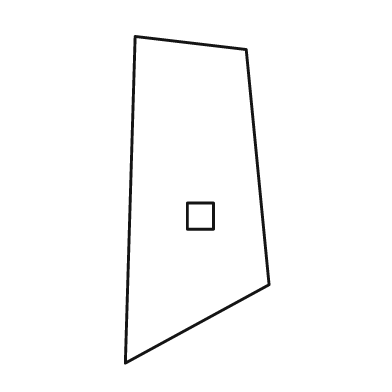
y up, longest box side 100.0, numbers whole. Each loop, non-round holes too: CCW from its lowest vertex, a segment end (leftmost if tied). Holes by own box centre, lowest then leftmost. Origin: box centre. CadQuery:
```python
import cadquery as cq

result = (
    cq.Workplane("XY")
    .moveTo(-22.0, -50.0)
    .lineTo(22.0, -26.0)
    .lineTo(15.0, 46.0)
    .lineTo(-19.0, 50.0)
    .close()
    .moveTo(-3.0, -9.0)
    .lineTo(5.0, -9.0)
    .lineTo(5.0, -1.0)
    .lineTo(-3.0, -1.0)
    .close()
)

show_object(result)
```